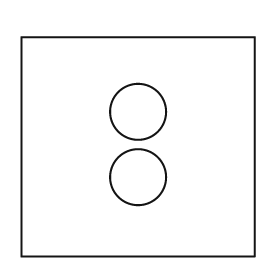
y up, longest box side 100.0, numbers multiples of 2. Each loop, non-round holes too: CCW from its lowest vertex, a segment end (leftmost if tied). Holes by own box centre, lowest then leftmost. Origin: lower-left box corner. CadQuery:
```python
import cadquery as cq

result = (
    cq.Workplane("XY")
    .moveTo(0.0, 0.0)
    .lineTo(100.0, 0.0)
    .lineTo(100.0, 94.0)
    .lineTo(0.0, 94.0)
    .close()
    .moveTo(50.0, 34.0)
    .circle(12.0)
    .moveTo(50.0, 62.0)
    .circle(12.0)
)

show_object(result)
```